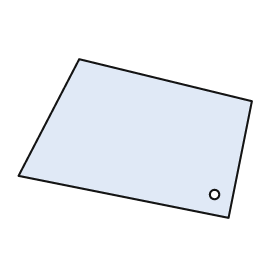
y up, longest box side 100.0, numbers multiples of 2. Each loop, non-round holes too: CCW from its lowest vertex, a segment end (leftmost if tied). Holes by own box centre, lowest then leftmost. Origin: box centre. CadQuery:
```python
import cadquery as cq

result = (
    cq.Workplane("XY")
    .moveTo(40.0, -34.0)
    .lineTo(50.0, 16.0)
    .lineTo(-24.0, 34.0)
    .lineTo(-50.0, -16.0)
    .close()
    .moveTo(34.0, -24.0)
    .circle(2.0)
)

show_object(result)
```